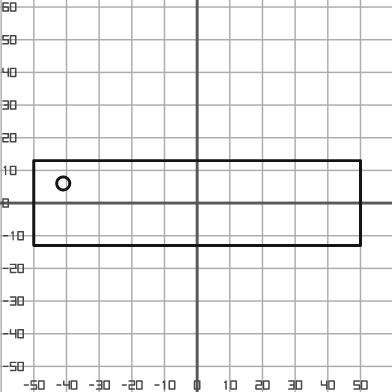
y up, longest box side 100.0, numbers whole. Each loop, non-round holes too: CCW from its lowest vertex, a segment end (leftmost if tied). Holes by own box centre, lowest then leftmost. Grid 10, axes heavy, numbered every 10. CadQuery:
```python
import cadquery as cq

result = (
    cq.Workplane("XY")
    .moveTo(-50.0, -13.0)
    .lineTo(50.0, -13.0)
    .lineTo(50.0, 13.0)
    .lineTo(-50.0, 13.0)
    .close()
    .moveTo(-41.0, 6.0)
    .circle(2.0)
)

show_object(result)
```